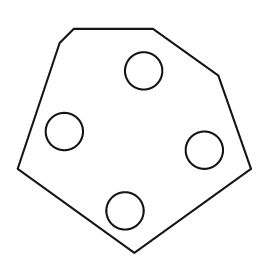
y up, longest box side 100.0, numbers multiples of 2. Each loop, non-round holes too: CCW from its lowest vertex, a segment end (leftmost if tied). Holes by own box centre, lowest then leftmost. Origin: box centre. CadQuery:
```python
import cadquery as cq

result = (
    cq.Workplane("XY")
    .moveTo(0.0, -48.0)
    .lineTo(50.0, -12.0)
    .lineTo(36.0, 28.0)
    .lineTo(8.0, 48.0)
    .lineTo(-26.0, 48.0)
    .lineTo(-32.0, 42.0)
    .lineTo(-50.0, -12.0)
    .close()
    .moveTo(-4.0, -30.0)
    .circle(8.0)
    .moveTo(30.0, -4.0)
    .circle(8.0)
    .moveTo(-30.0, 4.0)
    .circle(8.0)
    .moveTo(4.0, 30.0)
    .circle(8.0)
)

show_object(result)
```